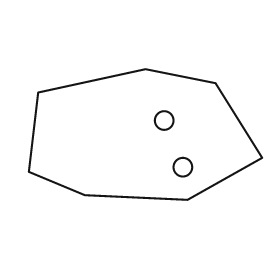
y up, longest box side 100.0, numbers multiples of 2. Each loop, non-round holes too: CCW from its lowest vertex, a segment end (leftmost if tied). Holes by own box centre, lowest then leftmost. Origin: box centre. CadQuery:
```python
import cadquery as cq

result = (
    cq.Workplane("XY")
    .moveTo(18.0, -28.0)
    .lineTo(50.0, -10.0)
    .lineTo(30.0, 22.0)
    .lineTo(0.0, 28.0)
    .lineTo(-46.0, 18.0)
    .lineTo(-50.0, -16.0)
    .lineTo(-26.0, -26.0)
    .close()
    .moveTo(16.0, -14.0)
    .circle(4.0)
    .moveTo(8.0, 6.0)
    .circle(4.0)
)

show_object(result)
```